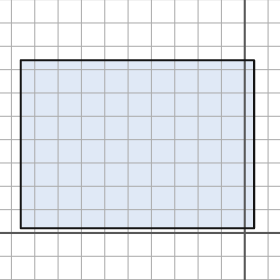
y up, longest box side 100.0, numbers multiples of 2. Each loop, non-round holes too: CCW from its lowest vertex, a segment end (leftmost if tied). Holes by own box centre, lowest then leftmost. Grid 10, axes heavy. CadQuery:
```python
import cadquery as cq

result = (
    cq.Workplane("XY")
    .moveTo(-96.0, 2.0)
    .lineTo(4.0, 2.0)
    .lineTo(4.0, 74.0)
    .lineTo(-96.0, 74.0)
    .close()
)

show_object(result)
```